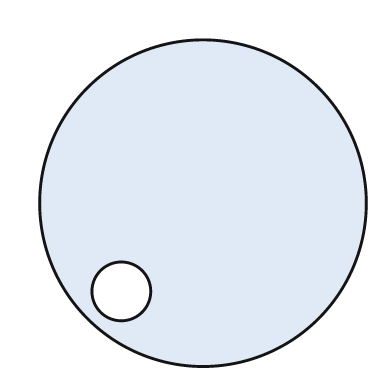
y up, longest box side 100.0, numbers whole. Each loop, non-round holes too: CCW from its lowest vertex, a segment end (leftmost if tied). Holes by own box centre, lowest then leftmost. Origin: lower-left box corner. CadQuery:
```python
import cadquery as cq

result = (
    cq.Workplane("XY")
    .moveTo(50.0, 50.0)
    .circle(50.0)
    .moveTo(25.0, 23.0)
    .circle(9.0)
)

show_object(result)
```